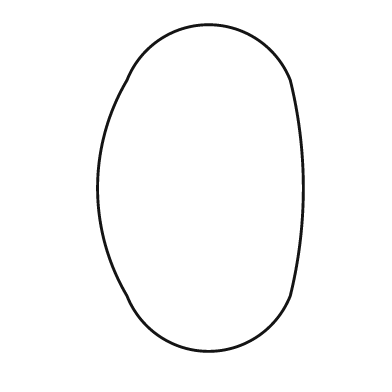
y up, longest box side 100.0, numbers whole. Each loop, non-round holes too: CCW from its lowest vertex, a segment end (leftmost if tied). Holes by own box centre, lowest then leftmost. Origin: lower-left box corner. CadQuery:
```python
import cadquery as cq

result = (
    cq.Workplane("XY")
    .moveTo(9.0, 17.0)
    .threePointArc((34.0, 0.0), (59.0, 17.0))
    .threePointArc((63.0, 50.0), (59.0, 83.0))
    .threePointArc((34.0, 100.0), (9.0, 83.0))
    .threePointArc((0.0, 50.0), (9.0, 17.0))
    .close()
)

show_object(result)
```